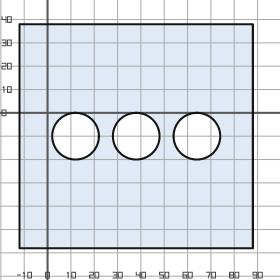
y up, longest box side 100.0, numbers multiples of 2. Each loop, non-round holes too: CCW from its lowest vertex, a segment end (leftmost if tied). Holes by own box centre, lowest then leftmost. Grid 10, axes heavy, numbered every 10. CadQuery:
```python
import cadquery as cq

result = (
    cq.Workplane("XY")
    .moveTo(-12.0, -58.0)
    .lineTo(88.0, -58.0)
    .lineTo(88.0, 38.0)
    .lineTo(-12.0, 38.0)
    .close()
    .moveTo(12.0, -10.0)
    .circle(10.0)
    .moveTo(38.0, -10.0)
    .circle(10.0)
    .moveTo(64.0, -10.0)
    .circle(10.0)
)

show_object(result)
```